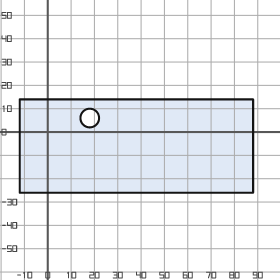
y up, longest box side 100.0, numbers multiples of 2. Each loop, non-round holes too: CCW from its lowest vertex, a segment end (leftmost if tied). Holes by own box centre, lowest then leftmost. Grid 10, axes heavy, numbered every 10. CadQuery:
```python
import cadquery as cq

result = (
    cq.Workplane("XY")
    .moveTo(-12.0, -26.0)
    .lineTo(88.0, -26.0)
    .lineTo(88.0, 14.0)
    .lineTo(-12.0, 14.0)
    .close()
    .moveTo(18.0, 6.0)
    .circle(4.0)
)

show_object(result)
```